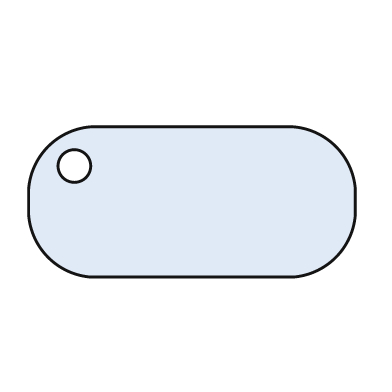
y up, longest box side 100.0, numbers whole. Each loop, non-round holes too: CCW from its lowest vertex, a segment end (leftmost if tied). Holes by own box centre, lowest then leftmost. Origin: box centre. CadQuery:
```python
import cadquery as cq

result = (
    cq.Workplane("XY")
    .moveTo(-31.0, -23.0)
    .lineTo(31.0, -23.0)
    .threePointArc((44.0, -17.0), (50.0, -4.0))
    .lineTo(50.0, 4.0)
    .threePointArc((44.0, 17.0), (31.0, 23.0))
    .lineTo(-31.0, 23.0)
    .threePointArc((-44.0, 17.0), (-50.0, 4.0))
    .lineTo(-50.0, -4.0)
    .threePointArc((-44.0, -17.0), (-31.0, -23.0))
    .close()
    .moveTo(-36.0, 11.0)
    .circle(5.0)
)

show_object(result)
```